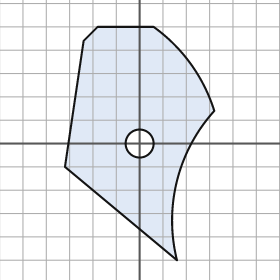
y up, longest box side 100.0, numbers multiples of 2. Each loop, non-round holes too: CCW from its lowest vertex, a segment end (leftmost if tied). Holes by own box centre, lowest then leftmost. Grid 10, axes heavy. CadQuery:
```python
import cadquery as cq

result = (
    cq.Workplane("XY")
    .moveTo(16.0, -50.0)
    .threePointArc((16.0, -16.0), (32.0, 14.0))
    .threePointArc((22.0, 34.0), (6.0, 50.0))
    .lineTo(-18.0, 50.0)
    .lineTo(-24.0, 44.0)
    .lineTo(-32.0, -10.0)
    .close()
    .moveTo(0.0, 0.0)
    .circle(6.0)
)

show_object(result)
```